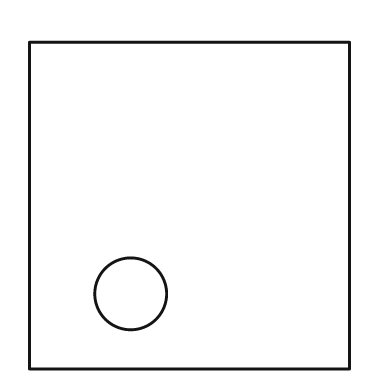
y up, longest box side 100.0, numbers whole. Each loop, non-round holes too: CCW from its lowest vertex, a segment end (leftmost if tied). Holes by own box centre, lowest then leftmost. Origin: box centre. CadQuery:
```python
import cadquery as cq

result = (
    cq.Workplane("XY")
    .moveTo(-49.0, -50.0)
    .lineTo(49.0, -50.0)
    .lineTo(49.0, 50.0)
    .lineTo(-49.0, 50.0)
    .close()
    .moveTo(-18.0, -27.0)
    .circle(11.0)
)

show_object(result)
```